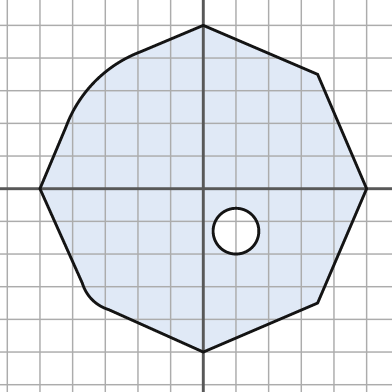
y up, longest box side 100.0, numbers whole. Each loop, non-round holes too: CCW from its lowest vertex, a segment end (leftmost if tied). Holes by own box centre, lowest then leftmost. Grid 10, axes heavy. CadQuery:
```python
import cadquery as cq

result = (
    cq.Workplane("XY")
    .moveTo(0.0, -50.0)
    .lineTo(35.0, -35.0)
    .lineTo(50.0, 0.0)
    .lineTo(35.0, 35.0)
    .lineTo(0.0, 50.0)
    .lineTo(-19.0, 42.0)
    .threePointArc((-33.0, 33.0), (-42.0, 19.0))
    .lineTo(-50.0, 0.0)
    .lineTo(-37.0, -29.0)
    .threePointArc((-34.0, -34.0), (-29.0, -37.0))
    .close()
    .moveTo(10.0, -13.0)
    .circle(7.0)
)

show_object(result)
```